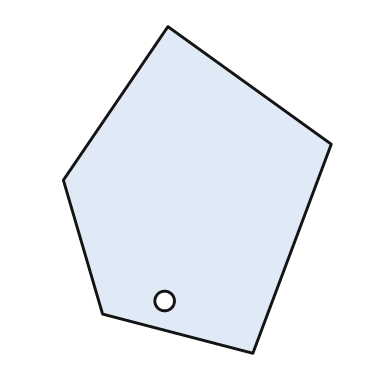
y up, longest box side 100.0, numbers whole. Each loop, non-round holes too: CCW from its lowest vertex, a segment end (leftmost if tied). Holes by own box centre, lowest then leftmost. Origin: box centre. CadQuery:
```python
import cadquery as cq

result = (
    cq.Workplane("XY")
    .moveTo(17.0, -50.0)
    .lineTo(41.0, 14.0)
    .lineTo(-9.0, 50.0)
    .lineTo(-41.0, 3.0)
    .lineTo(-29.0, -38.0)
    .close()
    .moveTo(-10.0, -34.0)
    .circle(3.0)
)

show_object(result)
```